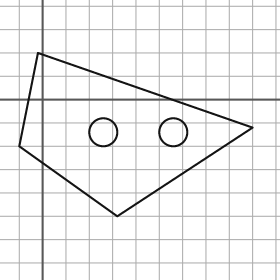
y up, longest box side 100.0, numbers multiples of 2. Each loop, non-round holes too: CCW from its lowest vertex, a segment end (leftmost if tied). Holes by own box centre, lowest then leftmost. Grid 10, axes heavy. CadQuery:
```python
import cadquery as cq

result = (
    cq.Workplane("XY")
    .moveTo(32.0, -50.0)
    .lineTo(90.0, -12.0)
    .lineTo(-2.0, 20.0)
    .lineTo(-10.0, -20.0)
    .close()
    .moveTo(26.0, -14.0)
    .circle(6.0)
    .moveTo(56.0, -14.0)
    .circle(6.0)
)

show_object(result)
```